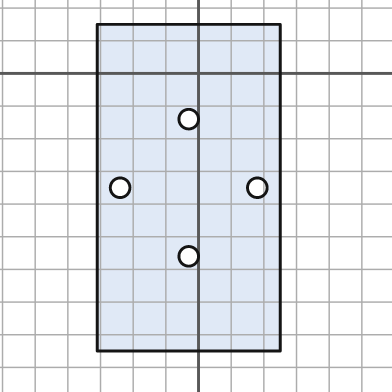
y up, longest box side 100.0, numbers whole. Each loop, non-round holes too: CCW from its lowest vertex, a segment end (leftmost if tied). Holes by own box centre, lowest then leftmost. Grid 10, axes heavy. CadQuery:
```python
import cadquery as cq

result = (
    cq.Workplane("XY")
    .moveTo(-31.0, -85.0)
    .lineTo(25.0, -85.0)
    .lineTo(25.0, 15.0)
    .lineTo(-31.0, 15.0)
    .close()
    .moveTo(-3.0, -56.0)
    .circle(3.0)
    .moveTo(-24.0, -35.0)
    .circle(3.0)
    .moveTo(18.0, -35.0)
    .circle(3.0)
    .moveTo(-3.0, -14.0)
    .circle(3.0)
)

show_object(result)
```